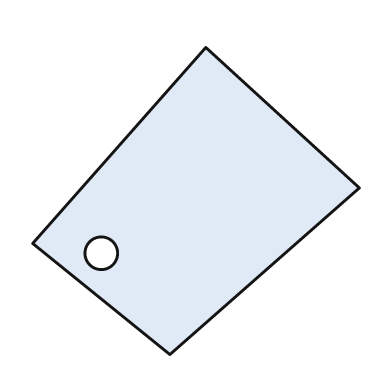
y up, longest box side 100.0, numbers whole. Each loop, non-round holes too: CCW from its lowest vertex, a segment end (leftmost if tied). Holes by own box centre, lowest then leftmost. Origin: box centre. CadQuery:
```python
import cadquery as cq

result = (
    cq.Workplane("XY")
    .moveTo(-8.0, -47.0)
    .lineTo(50.0, 4.0)
    .lineTo(3.0, 47.0)
    .lineTo(-50.0, -13.0)
    .close()
    .moveTo(-29.0, -16.0)
    .circle(5.0)
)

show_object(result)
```